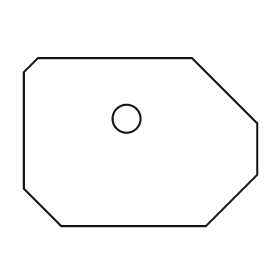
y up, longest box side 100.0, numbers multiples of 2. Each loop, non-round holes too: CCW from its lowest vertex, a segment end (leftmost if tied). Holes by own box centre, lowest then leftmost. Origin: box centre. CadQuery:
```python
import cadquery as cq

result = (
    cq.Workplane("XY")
    .moveTo(-34.0, -36.0)
    .lineTo(28.0, -36.0)
    .lineTo(50.0, -14.0)
    .lineTo(50.0, 8.0)
    .lineTo(22.0, 36.0)
    .lineTo(-44.0, 36.0)
    .lineTo(-50.0, 30.0)
    .lineTo(-50.0, -20.0)
    .close()
    .moveTo(-6.0, 10.0)
    .circle(6.0)
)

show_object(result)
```